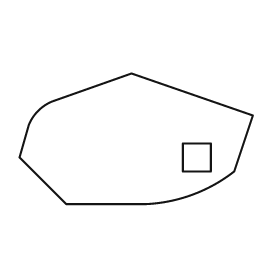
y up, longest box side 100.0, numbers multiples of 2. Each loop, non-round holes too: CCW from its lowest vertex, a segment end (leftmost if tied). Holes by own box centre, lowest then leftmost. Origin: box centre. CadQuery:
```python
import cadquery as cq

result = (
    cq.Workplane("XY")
    .moveTo(-30.0, -28.0)
    .lineTo(4.0, -28.0)
    .threePointArc((24.0, -24.0), (42.0, -14.0))
    .lineTo(50.0, 10.0)
    .lineTo(-2.0, 28.0)
    .lineTo(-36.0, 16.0)
    .threePointArc((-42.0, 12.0), (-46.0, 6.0))
    .lineTo(-50.0, -8.0)
    .close()
    .moveTo(20.0, -14.0)
    .lineTo(32.0, -14.0)
    .lineTo(32.0, -2.0)
    .lineTo(20.0, -2.0)
    .close()
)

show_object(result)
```